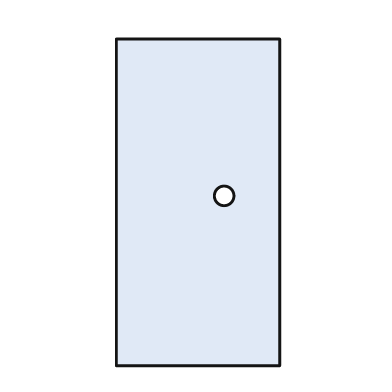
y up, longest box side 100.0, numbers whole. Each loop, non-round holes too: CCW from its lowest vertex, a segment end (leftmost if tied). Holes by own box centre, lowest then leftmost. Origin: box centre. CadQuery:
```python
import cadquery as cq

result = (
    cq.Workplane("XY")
    .moveTo(-25.0, -50.0)
    .lineTo(25.0, -50.0)
    .lineTo(25.0, 50.0)
    .lineTo(-25.0, 50.0)
    .close()
    .moveTo(8.0, 2.0)
    .circle(3.0)
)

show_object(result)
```